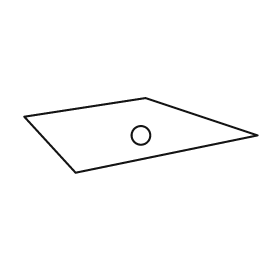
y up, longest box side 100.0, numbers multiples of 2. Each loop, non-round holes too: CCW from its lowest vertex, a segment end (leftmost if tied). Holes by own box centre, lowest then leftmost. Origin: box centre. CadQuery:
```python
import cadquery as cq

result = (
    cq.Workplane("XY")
    .moveTo(-28.0, -16.0)
    .lineTo(50.0, 0.0)
    .lineTo(2.0, 16.0)
    .lineTo(-50.0, 8.0)
    .close()
    .moveTo(0.0, 0.0)
    .circle(4.0)
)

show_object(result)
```